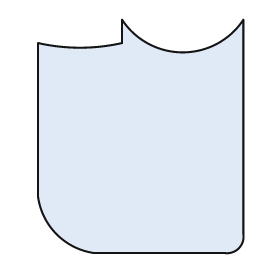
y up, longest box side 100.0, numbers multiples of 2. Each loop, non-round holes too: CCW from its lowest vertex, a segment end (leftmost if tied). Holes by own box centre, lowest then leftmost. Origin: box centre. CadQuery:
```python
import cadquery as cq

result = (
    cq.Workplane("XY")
    .moveTo(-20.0, -50.0)
    .lineTo(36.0, -50.0)
    .threePointArc((42.0, -48.0), (44.0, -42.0))
    .lineTo(44.0, 50.0)
    .threePointArc((18.0, 36.0), (-8.0, 50.0))
    .lineTo(-8.0, 40.0)
    .threePointArc((-26.0, 38.0), (-44.0, 40.0))
    .lineTo(-44.0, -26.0)
    .threePointArc((-36.0, -42.0), (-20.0, -50.0))
    .close()
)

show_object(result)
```